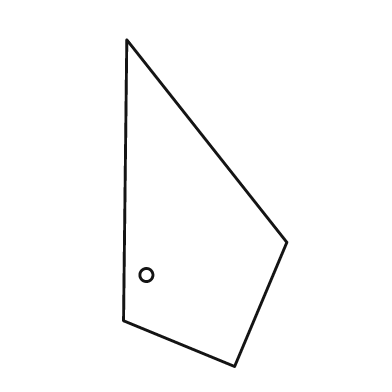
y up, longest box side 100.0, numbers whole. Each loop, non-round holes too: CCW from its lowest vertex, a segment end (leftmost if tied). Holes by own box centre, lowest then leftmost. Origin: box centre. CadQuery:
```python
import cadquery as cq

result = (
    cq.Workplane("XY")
    .moveTo(9.0, -50.0)
    .lineTo(25.0, -12.0)
    .lineTo(-24.0, 50.0)
    .lineTo(-25.0, -36.0)
    .close()
    .moveTo(-18.0, -22.0)
    .circle(2.0)
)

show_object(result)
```